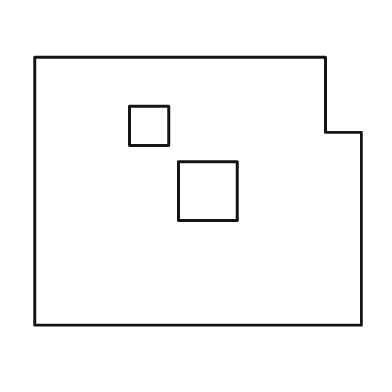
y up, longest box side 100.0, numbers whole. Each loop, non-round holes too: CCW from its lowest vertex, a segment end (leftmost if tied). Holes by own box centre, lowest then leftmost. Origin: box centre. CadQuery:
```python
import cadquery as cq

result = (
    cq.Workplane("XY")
    .moveTo(-50.0, -41.0)
    .lineTo(50.0, -41.0)
    .lineTo(50.0, 18.0)
    .lineTo(39.0, 18.0)
    .lineTo(39.0, 41.0)
    .lineTo(-50.0, 41.0)
    .close()
    .moveTo(-6.0, -9.0)
    .lineTo(12.0, -9.0)
    .lineTo(12.0, 9.0)
    .lineTo(-6.0, 9.0)
    .close()
    .moveTo(-21.0, 14.0)
    .lineTo(-9.0, 14.0)
    .lineTo(-9.0, 26.0)
    .lineTo(-21.0, 26.0)
    .close()
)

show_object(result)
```